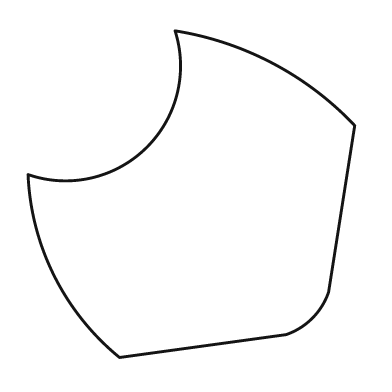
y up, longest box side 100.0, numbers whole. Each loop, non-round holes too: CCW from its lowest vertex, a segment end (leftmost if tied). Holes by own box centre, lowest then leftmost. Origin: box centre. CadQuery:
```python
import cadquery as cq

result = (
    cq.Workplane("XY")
    .moveTo(-22.0, -50.0)
    .lineTo(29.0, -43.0)
    .threePointArc((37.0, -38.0), (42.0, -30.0))
    .lineTo(50.0, 21.0)
    .threePointArc((25.0, 40.0), (-5.0, 50.0))
    .threePointArc((-14.0, 14.0), (-50.0, 6.0))
    .threePointArc((-42.0, -25.0), (-22.0, -50.0))
    .close()
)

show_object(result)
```